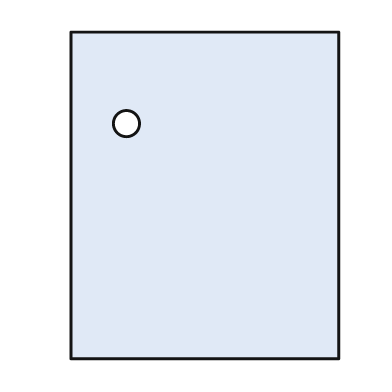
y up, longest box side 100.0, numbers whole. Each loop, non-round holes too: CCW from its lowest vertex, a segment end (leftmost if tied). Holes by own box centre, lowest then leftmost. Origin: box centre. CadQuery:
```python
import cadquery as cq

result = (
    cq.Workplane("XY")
    .moveTo(-41.0, -50.0)
    .lineTo(41.0, -50.0)
    .lineTo(41.0, 50.0)
    .lineTo(-41.0, 50.0)
    .close()
    .moveTo(-24.0, 22.0)
    .circle(4.0)
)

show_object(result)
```